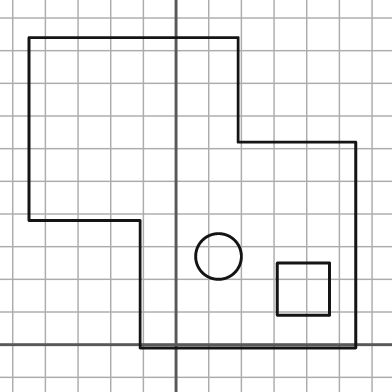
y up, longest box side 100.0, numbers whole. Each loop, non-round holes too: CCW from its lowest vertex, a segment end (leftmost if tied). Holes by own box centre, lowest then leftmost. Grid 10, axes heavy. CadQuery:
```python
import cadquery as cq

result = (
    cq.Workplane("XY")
    .moveTo(-11.0, -1.0)
    .lineTo(55.0, -1.0)
    .lineTo(55.0, 62.0)
    .lineTo(19.0, 62.0)
    .lineTo(19.0, 94.0)
    .lineTo(-45.0, 94.0)
    .lineTo(-45.0, 38.0)
    .lineTo(-11.0, 38.0)
    .close()
    .moveTo(31.0, 9.0)
    .lineTo(47.0, 9.0)
    .lineTo(47.0, 25.0)
    .lineTo(31.0, 25.0)
    .close()
    .moveTo(13.0, 27.0)
    .circle(7.0)
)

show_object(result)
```